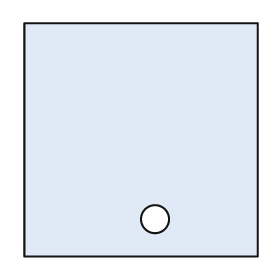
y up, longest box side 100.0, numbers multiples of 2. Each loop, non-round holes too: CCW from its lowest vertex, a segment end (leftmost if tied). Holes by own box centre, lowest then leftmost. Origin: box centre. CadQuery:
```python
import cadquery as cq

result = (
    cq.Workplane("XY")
    .moveTo(-50.0, -50.0)
    .lineTo(50.0, -50.0)
    .lineTo(50.0, 50.0)
    .lineTo(-50.0, 50.0)
    .close()
    .moveTo(6.0, -34.0)
    .circle(6.0)
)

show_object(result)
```